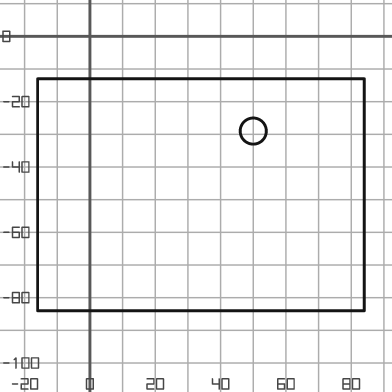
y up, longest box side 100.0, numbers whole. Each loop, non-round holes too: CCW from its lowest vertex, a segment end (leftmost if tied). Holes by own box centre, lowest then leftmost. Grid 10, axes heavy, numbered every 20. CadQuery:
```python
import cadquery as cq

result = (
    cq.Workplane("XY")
    .moveTo(-16.0, -84.0)
    .lineTo(84.0, -84.0)
    .lineTo(84.0, -13.0)
    .lineTo(-16.0, -13.0)
    .close()
    .moveTo(50.0, -29.0)
    .circle(4.0)
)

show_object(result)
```